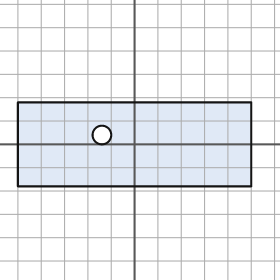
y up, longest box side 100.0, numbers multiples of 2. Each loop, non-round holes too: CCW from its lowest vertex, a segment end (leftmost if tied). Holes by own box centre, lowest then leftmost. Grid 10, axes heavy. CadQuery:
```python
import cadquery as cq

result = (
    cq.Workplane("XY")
    .moveTo(-50.0, -18.0)
    .lineTo(50.0, -18.0)
    .lineTo(50.0, 18.0)
    .lineTo(-50.0, 18.0)
    .close()
    .moveTo(-14.0, 4.0)
    .circle(4.0)
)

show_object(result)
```